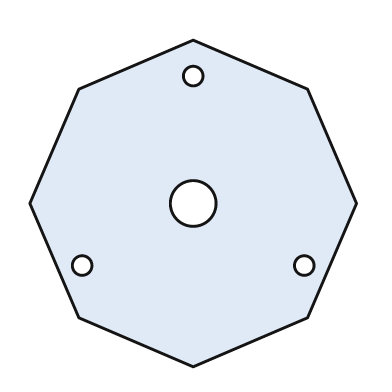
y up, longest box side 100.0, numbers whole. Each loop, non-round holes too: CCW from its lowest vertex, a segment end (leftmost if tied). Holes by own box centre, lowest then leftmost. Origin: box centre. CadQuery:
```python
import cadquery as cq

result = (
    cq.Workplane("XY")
    .moveTo(0.0, -50.0)
    .lineTo(35.0, -35.0)
    .lineTo(50.0, 0.0)
    .lineTo(35.0, 35.0)
    .lineTo(0.0, 50.0)
    .lineTo(-35.0, 35.0)
    .lineTo(-50.0, 0.0)
    .lineTo(-35.0, -35.0)
    .close()
    .moveTo(-34.0, -19.0)
    .circle(3.0)
    .moveTo(34.0, -19.0)
    .circle(3.0)
    .moveTo(0.0, 0.0)
    .circle(7.0)
    .moveTo(0.0, 39.0)
    .circle(3.0)
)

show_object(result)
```